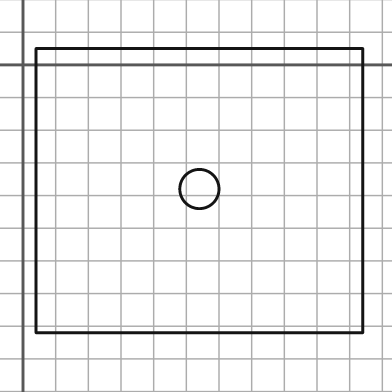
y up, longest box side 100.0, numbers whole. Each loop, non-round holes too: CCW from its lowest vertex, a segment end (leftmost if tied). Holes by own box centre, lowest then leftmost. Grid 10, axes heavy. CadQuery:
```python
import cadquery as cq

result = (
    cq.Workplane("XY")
    .moveTo(4.0, -82.0)
    .lineTo(104.0, -82.0)
    .lineTo(104.0, 5.0)
    .lineTo(4.0, 5.0)
    .close()
    .moveTo(54.0, -38.0)
    .circle(6.0)
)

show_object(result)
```